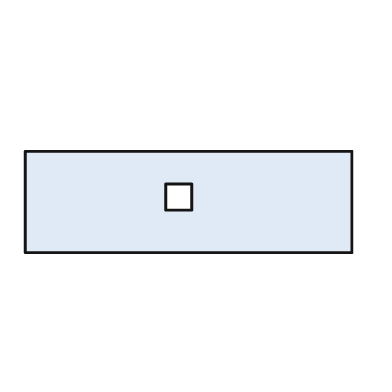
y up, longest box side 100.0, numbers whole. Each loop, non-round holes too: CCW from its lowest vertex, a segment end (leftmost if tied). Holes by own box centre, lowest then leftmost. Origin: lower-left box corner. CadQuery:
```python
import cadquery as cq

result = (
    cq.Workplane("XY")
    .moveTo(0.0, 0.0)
    .lineTo(100.0, 0.0)
    .lineTo(100.0, 31.0)
    .lineTo(0.0, 31.0)
    .close()
    .moveTo(43.0, 13.0)
    .lineTo(51.0, 13.0)
    .lineTo(51.0, 21.0)
    .lineTo(43.0, 21.0)
    .close()
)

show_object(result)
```